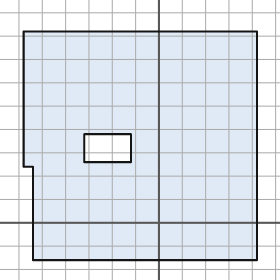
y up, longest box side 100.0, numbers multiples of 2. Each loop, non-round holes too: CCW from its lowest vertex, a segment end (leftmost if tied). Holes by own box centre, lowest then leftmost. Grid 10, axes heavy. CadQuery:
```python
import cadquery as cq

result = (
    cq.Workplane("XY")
    .moveTo(-54.0, -16.0)
    .lineTo(42.0, -16.0)
    .lineTo(42.0, 82.0)
    .lineTo(-58.0, 82.0)
    .lineTo(-58.0, 24.0)
    .lineTo(-54.0, 24.0)
    .close()
    .moveTo(-32.0, 26.0)
    .lineTo(-12.0, 26.0)
    .lineTo(-12.0, 38.0)
    .lineTo(-32.0, 38.0)
    .close()
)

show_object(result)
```